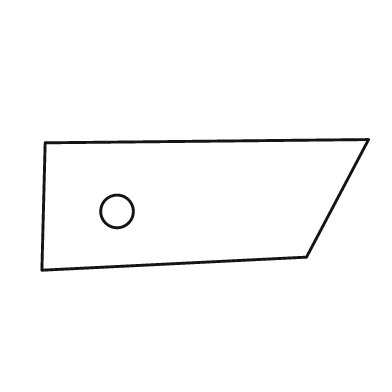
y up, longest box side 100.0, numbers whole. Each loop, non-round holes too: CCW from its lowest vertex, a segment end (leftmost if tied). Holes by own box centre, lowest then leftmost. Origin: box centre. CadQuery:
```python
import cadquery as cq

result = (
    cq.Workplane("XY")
    .moveTo(-50.0, -20.0)
    .lineTo(31.0, -16.0)
    .lineTo(50.0, 20.0)
    .lineTo(-49.0, 19.0)
    .close()
    .moveTo(-27.0, -2.0)
    .circle(5.0)
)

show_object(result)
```